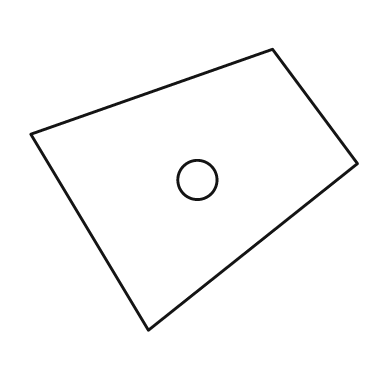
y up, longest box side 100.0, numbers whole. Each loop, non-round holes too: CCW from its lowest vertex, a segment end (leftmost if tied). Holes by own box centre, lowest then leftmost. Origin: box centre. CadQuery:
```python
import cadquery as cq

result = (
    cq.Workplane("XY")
    .moveTo(-14.0, -43.0)
    .lineTo(50.0, 8.0)
    .lineTo(24.0, 43.0)
    .lineTo(-50.0, 17.0)
    .close()
    .moveTo(1.0, 3.0)
    .circle(6.0)
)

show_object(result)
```